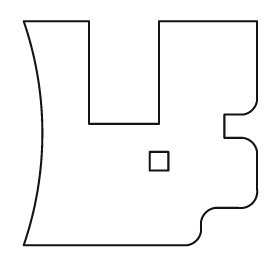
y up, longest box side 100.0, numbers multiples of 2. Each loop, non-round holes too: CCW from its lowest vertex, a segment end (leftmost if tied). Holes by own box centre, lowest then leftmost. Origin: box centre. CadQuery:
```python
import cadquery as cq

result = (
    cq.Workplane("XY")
    .moveTo(-50.0, -48.0)
    .lineTo(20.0, -48.0)
    .threePointArc((24.0, -46.0), (26.0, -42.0))
    .lineTo(26.0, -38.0)
    .threePointArc((28.0, -34.0), (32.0, -32.0))
    .lineTo(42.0, -32.0)
    .threePointArc((48.0, -30.0), (50.0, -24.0))
    .lineTo(50.0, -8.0)
    .threePointArc((48.0, -4.0), (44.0, -2.0))
    .lineTo(36.0, -2.0)
    .lineTo(36.0, 8.0)
    .lineTo(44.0, 8.0)
    .threePointArc((48.0, 10.0), (50.0, 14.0))
    .lineTo(50.0, 48.0)
    .lineTo(8.0, 48.0)
    .lineTo(8.0, 4.0)
    .lineTo(-22.0, 4.0)
    .lineTo(-22.0, 48.0)
    .lineTo(-50.0, 48.0)
    .threePointArc((-42.0, 0.0), (-50.0, -48.0))
    .close()
    .moveTo(4.0, -16.0)
    .lineTo(12.0, -16.0)
    .lineTo(12.0, -8.0)
    .lineTo(4.0, -8.0)
    .close()
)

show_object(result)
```